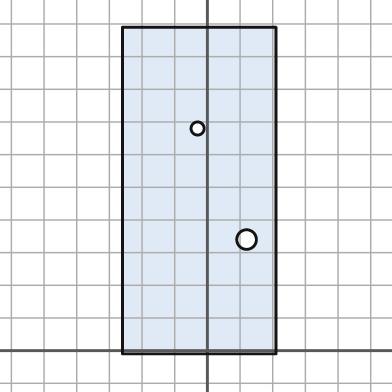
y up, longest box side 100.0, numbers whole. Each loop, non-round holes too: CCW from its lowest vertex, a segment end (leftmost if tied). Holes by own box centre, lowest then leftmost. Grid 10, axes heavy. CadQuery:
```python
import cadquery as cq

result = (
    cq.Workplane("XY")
    .moveTo(-26.0, -1.0)
    .lineTo(21.0, -1.0)
    .lineTo(21.0, 99.0)
    .lineTo(-26.0, 99.0)
    .close()
    .moveTo(12.0, 34.0)
    .circle(3.0)
    .moveTo(-3.0, 68.0)
    .circle(2.0)
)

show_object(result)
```